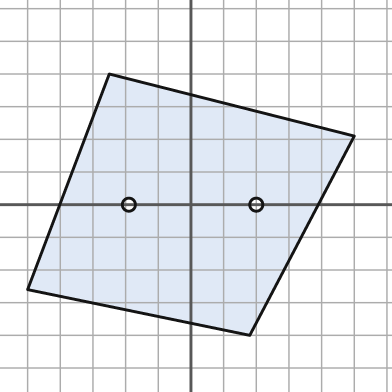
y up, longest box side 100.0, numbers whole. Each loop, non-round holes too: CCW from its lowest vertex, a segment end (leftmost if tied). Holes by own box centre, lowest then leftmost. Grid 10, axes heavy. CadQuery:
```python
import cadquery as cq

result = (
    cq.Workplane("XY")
    .moveTo(18.0, -40.0)
    .lineTo(50.0, 21.0)
    .lineTo(-25.0, 40.0)
    .lineTo(-50.0, -26.0)
    .close()
    .moveTo(-19.0, 0.0)
    .circle(2.0)
    .moveTo(20.0, 0.0)
    .circle(2.0)
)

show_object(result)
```